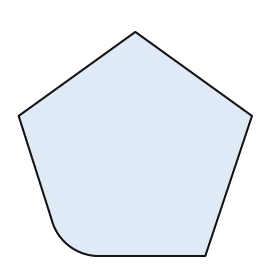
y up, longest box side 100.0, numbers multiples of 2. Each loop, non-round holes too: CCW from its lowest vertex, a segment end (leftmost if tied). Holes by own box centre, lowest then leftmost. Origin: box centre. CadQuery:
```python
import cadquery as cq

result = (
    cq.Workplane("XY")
    .moveTo(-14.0, -48.0)
    .lineTo(30.0, -48.0)
    .lineTo(50.0, 12.0)
    .lineTo(0.0, 48.0)
    .lineTo(-50.0, 12.0)
    .lineTo(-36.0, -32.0)
    .threePointArc((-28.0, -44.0), (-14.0, -48.0))
    .close()
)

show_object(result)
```